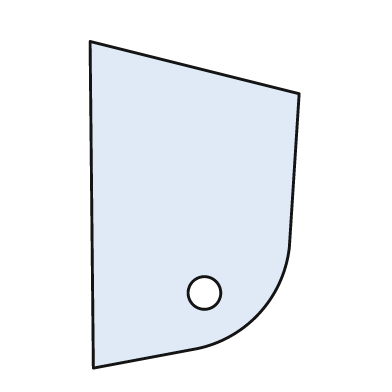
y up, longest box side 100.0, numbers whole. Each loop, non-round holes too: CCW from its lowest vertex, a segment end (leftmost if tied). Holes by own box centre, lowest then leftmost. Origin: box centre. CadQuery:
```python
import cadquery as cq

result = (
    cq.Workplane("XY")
    .moveTo(-31.0, -50.0)
    .lineTo(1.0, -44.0)
    .threePointArc((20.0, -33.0), (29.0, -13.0))
    .lineTo(32.0, 34.0)
    .lineTo(-32.0, 50.0)
    .close()
    .moveTo(3.0, -27.0)
    .circle(5.0)
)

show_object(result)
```